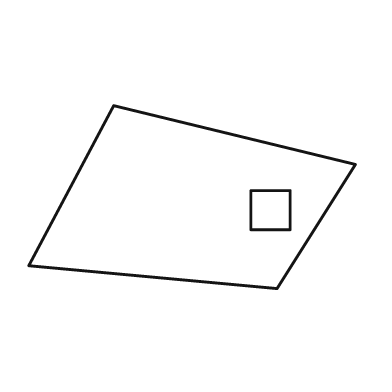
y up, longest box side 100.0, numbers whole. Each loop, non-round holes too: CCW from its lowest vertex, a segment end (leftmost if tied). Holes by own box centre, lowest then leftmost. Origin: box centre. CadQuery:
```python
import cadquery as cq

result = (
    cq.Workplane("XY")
    .moveTo(26.0, -28.0)
    .lineTo(50.0, 10.0)
    .lineTo(-24.0, 28.0)
    .lineTo(-50.0, -21.0)
    .close()
    .moveTo(18.0, -10.0)
    .lineTo(30.0, -10.0)
    .lineTo(30.0, 2.0)
    .lineTo(18.0, 2.0)
    .close()
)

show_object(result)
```